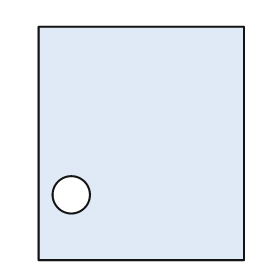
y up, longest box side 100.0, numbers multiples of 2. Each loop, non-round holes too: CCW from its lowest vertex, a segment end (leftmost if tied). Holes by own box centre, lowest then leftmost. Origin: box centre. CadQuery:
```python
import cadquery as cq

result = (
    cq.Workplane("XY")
    .moveTo(-44.0, -50.0)
    .lineTo(44.0, -50.0)
    .lineTo(44.0, 50.0)
    .lineTo(-44.0, 50.0)
    .close()
    .moveTo(-30.0, -22.0)
    .circle(8.0)
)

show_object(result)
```